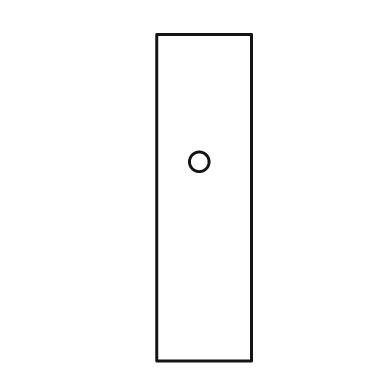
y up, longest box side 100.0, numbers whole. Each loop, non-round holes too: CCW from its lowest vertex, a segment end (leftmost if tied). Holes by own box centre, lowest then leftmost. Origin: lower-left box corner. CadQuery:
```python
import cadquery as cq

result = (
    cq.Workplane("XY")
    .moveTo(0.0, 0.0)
    .lineTo(29.0, 0.0)
    .lineTo(29.0, 100.0)
    .lineTo(0.0, 100.0)
    .close()
    .moveTo(13.0, 61.0)
    .circle(3.0)
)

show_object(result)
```